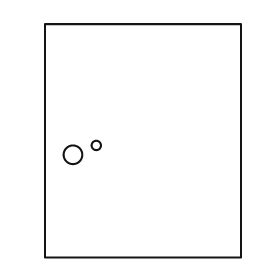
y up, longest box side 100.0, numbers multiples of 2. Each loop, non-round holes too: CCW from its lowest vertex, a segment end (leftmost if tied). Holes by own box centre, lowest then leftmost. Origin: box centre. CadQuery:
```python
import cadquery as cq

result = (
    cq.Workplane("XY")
    .moveTo(-42.0, -50.0)
    .lineTo(42.0, -50.0)
    .lineTo(42.0, 50.0)
    .lineTo(-42.0, 50.0)
    .close()
    .moveTo(-30.0, -6.0)
    .circle(4.0)
    .moveTo(-20.0, -2.0)
    .circle(2.0)
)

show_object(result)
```